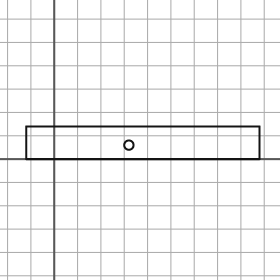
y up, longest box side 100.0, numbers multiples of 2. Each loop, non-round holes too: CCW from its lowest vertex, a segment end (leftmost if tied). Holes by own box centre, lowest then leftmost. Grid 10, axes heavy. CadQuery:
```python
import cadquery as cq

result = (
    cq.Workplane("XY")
    .moveTo(-12.0, 0.0)
    .lineTo(88.0, 0.0)
    .lineTo(88.0, 14.0)
    .lineTo(-12.0, 14.0)
    .close()
    .moveTo(32.0, 6.0)
    .circle(2.0)
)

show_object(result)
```